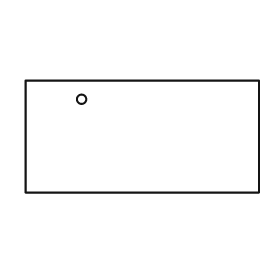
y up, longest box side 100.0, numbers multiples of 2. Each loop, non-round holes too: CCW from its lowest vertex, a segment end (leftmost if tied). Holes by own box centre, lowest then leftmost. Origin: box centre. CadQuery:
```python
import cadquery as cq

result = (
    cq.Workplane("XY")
    .moveTo(-50.0, -24.0)
    .lineTo(50.0, -24.0)
    .lineTo(50.0, 24.0)
    .lineTo(-50.0, 24.0)
    .close()
    .moveTo(-26.0, 16.0)
    .circle(2.0)
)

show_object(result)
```